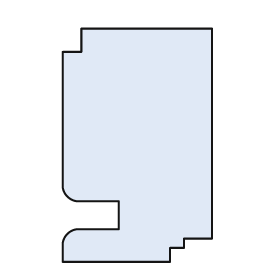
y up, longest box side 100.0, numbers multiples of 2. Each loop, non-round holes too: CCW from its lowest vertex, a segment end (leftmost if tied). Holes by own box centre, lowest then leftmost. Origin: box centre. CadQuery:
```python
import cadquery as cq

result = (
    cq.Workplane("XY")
    .moveTo(-32.0, -50.0)
    .lineTo(14.0, -50.0)
    .lineTo(14.0, -44.0)
    .lineTo(20.0, -44.0)
    .lineTo(20.0, -40.0)
    .lineTo(32.0, -40.0)
    .lineTo(32.0, 50.0)
    .lineTo(-24.0, 50.0)
    .lineTo(-24.0, 40.0)
    .lineTo(-32.0, 40.0)
    .lineTo(-32.0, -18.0)
    .threePointArc((-30.0, -22.0), (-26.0, -24.0))
    .lineTo(-8.0, -24.0)
    .lineTo(-8.0, -36.0)
    .lineTo(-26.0, -36.0)
    .threePointArc((-30.0, -38.0), (-32.0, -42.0))
    .close()
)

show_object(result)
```